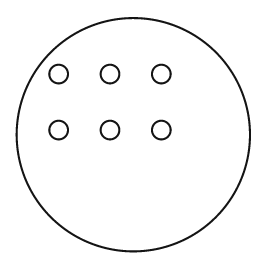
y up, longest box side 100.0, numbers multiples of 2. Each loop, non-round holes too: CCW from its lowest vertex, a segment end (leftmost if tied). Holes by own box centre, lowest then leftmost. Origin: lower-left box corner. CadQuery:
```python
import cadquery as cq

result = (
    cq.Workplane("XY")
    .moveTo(50.0, 50.0)
    .circle(50.0)
    .moveTo(18.0, 52.0)
    .circle(4.0)
    .moveTo(40.0, 52.0)
    .circle(4.0)
    .moveTo(62.0, 52.0)
    .circle(4.0)
    .moveTo(18.0, 76.0)
    .circle(4.0)
    .moveTo(40.0, 76.0)
    .circle(4.0)
    .moveTo(62.0, 76.0)
    .circle(4.0)
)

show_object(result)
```